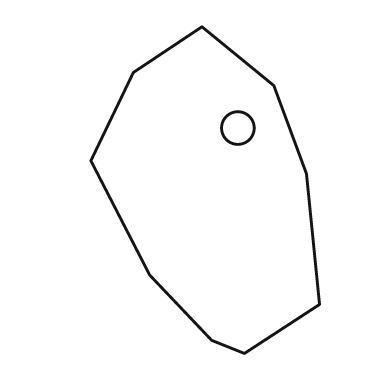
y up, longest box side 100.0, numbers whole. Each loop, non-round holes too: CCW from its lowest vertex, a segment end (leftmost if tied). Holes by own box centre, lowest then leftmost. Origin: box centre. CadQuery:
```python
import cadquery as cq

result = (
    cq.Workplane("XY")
    .moveTo(12.0, -50.0)
    .lineTo(35.0, -35.0)
    .lineTo(31.0, 5.0)
    .lineTo(21.0, 32.0)
    .lineTo(-1.0, 50.0)
    .lineTo(-22.0, 36.0)
    .lineTo(-35.0, 9.0)
    .lineTo(-17.0, -26.0)
    .lineTo(2.0, -46.0)
    .close()
    .moveTo(10.0, 19.0)
    .circle(5.0)
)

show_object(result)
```